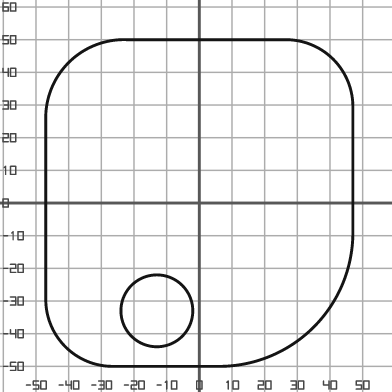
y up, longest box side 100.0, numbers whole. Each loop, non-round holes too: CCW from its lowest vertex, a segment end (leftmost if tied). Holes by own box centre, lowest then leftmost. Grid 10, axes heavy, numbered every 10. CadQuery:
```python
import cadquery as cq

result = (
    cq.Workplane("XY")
    .moveTo(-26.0, -50.0)
    .lineTo(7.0, -50.0)
    .threePointArc((35.0, -38.0), (47.0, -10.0))
    .lineTo(47.0, 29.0)
    .threePointArc((41.0, 44.0), (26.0, 50.0))
    .lineTo(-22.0, 50.0)
    .threePointArc((-40.0, 43.0), (-47.0, 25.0))
    .lineTo(-47.0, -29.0)
    .threePointArc((-41.0, -44.0), (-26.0, -50.0))
    .close()
    .moveTo(-13.0, -33.0)
    .circle(11.0)
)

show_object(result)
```